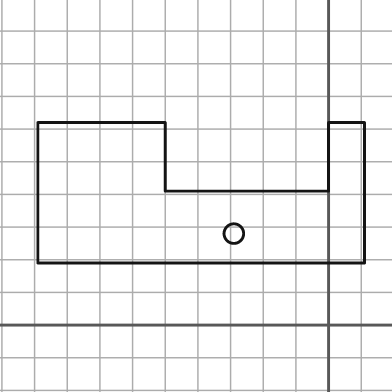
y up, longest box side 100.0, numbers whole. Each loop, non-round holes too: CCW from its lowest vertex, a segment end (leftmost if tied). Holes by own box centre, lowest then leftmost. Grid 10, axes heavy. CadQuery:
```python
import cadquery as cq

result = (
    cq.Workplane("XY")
    .moveTo(-89.0, 19.0)
    .lineTo(11.0, 19.0)
    .lineTo(11.0, 62.0)
    .lineTo(0.0, 62.0)
    .lineTo(0.0, 41.0)
    .lineTo(-50.0, 41.0)
    .lineTo(-50.0, 62.0)
    .lineTo(-89.0, 62.0)
    .close()
    .moveTo(-29.0, 28.0)
    .circle(3.0)
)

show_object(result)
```